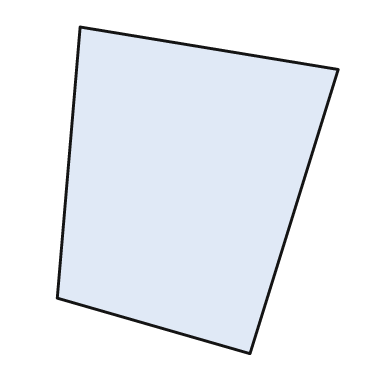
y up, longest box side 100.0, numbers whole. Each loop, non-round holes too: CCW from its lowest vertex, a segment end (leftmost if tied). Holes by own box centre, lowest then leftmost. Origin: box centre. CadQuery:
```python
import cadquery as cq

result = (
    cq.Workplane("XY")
    .moveTo(16.0, -50.0)
    .lineTo(43.0, 37.0)
    .lineTo(-36.0, 50.0)
    .lineTo(-43.0, -33.0)
    .close()
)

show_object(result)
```